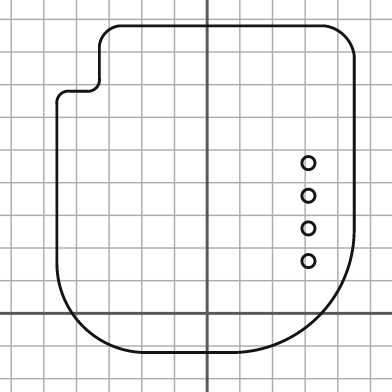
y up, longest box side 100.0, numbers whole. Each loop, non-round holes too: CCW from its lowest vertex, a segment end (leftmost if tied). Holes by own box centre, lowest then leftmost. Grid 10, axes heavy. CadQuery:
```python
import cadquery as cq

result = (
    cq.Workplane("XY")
    .moveTo(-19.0, -12.0)
    .lineTo(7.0, -12.0)
    .threePointArc((34.0, -1.0), (45.0, 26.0))
    .lineTo(45.0, 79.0)
    .threePointArc((42.0, 85.0), (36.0, 88.0))
    .lineTo(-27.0, 88.0)
    .threePointArc((-31.0, 86.0), (-33.0, 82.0))
    .lineTo(-33.0, 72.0)
    .threePointArc((-34.0, 69.0), (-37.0, 68.0))
    .lineTo(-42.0, 68.0)
    .threePointArc((-45.0, 67.0), (-46.0, 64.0))
    .lineTo(-46.0, 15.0)
    .threePointArc((-38.0, -4.0), (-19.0, -12.0))
    .close()
    .moveTo(31.0, 16.0)
    .circle(2.0)
    .moveTo(31.0, 26.0)
    .circle(2.0)
    .moveTo(31.0, 36.0)
    .circle(2.0)
    .moveTo(31.0, 46.0)
    .circle(2.0)
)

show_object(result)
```